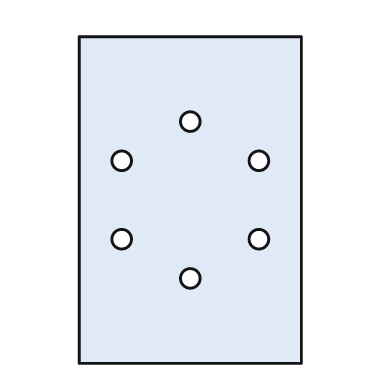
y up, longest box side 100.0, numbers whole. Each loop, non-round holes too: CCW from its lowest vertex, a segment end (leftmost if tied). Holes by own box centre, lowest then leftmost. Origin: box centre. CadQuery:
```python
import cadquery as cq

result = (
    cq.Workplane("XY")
    .moveTo(-34.0, -50.0)
    .lineTo(34.0, -50.0)
    .lineTo(34.0, 50.0)
    .lineTo(-34.0, 50.0)
    .close()
    .moveTo(0.0, -24.0)
    .circle(3.0)
    .moveTo(-21.0, -12.0)
    .circle(3.0)
    .moveTo(21.0, -12.0)
    .circle(3.0)
    .moveTo(-21.0, 12.0)
    .circle(3.0)
    .moveTo(21.0, 12.0)
    .circle(3.0)
    .moveTo(0.0, 24.0)
    .circle(3.0)
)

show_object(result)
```